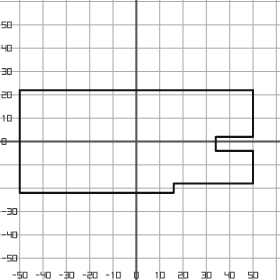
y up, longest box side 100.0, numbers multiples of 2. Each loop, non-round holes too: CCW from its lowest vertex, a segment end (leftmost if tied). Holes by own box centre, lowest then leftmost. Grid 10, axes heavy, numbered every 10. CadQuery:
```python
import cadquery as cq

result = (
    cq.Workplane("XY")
    .moveTo(-50.0, -22.0)
    .lineTo(16.0, -22.0)
    .lineTo(16.0, -18.0)
    .lineTo(50.0, -18.0)
    .lineTo(50.0, -4.0)
    .lineTo(34.0, -4.0)
    .lineTo(34.0, 2.0)
    .lineTo(50.0, 2.0)
    .lineTo(50.0, 22.0)
    .lineTo(-50.0, 22.0)
    .close()
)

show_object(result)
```